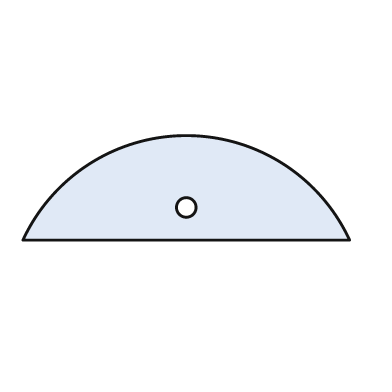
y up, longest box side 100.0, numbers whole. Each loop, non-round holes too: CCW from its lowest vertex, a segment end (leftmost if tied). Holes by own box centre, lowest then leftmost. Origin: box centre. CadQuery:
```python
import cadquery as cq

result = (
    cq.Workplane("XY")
    .moveTo(-50.0, -16.0)
    .lineTo(50.0, -16.0)
    .threePointArc((0.0, 16.0), (-50.0, -16.0))
    .close()
    .moveTo(0.0, -6.0)
    .circle(3.0)
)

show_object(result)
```